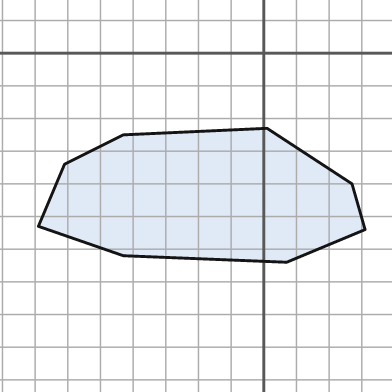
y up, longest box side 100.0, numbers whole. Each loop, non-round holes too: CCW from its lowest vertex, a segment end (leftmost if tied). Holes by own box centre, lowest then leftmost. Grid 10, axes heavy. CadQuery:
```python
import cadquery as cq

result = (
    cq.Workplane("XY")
    .moveTo(7.0, -64.0)
    .lineTo(31.0, -54.0)
    .lineTo(27.0, -40.0)
    .lineTo(1.0, -23.0)
    .lineTo(-43.0, -25.0)
    .lineTo(-61.0, -34.0)
    .lineTo(-69.0, -53.0)
    .lineTo(-43.0, -62.0)
    .close()
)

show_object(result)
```